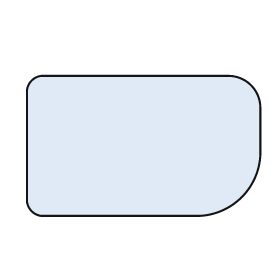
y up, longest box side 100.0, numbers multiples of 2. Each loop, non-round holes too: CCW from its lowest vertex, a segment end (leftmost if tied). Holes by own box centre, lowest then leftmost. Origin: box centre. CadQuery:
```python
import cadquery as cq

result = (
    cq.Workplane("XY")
    .moveTo(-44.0, -30.0)
    .lineTo(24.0, -30.0)
    .threePointArc((42.0, -22.0), (50.0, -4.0))
    .lineTo(50.0, 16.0)
    .threePointArc((46.0, 26.0), (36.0, 30.0))
    .lineTo(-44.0, 30.0)
    .threePointArc((-48.0, 28.0), (-50.0, 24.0))
    .lineTo(-50.0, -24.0)
    .threePointArc((-48.0, -28.0), (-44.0, -30.0))
    .close()
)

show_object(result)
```